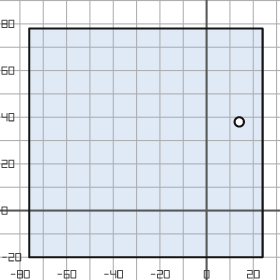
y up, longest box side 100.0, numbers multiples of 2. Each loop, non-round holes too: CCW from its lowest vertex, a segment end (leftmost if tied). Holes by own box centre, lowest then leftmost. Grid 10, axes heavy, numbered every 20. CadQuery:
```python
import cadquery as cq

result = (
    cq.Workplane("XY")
    .moveTo(-76.0, -20.0)
    .lineTo(24.0, -20.0)
    .lineTo(24.0, 78.0)
    .lineTo(-76.0, 78.0)
    .close()
    .moveTo(14.0, 38.0)
    .circle(2.0)
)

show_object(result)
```